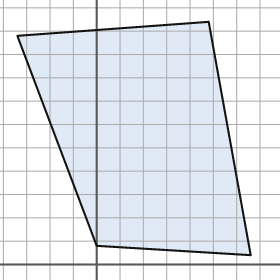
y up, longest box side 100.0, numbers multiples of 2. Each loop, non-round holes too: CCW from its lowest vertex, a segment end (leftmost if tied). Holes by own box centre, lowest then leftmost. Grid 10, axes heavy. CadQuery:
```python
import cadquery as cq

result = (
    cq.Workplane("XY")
    .moveTo(66.0, 4.0)
    .lineTo(48.0, 104.0)
    .lineTo(-34.0, 98.0)
    .lineTo(0.0, 8.0)
    .close()
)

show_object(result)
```